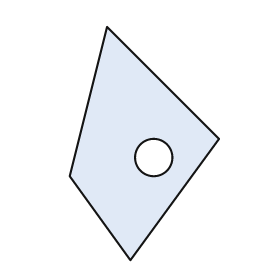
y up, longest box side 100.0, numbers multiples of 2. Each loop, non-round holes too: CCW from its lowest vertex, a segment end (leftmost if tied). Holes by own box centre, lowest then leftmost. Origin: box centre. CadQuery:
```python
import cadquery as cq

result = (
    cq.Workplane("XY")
    .moveTo(-6.0, -50.0)
    .lineTo(32.0, 2.0)
    .lineTo(-16.0, 50.0)
    .lineTo(-32.0, -14.0)
    .close()
    .moveTo(4.0, -6.0)
    .circle(8.0)
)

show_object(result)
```